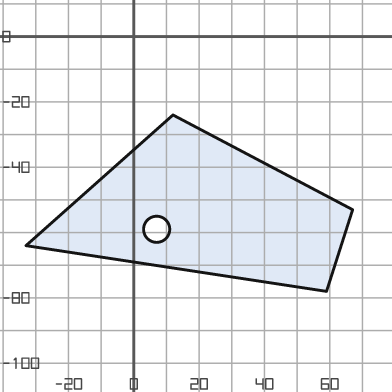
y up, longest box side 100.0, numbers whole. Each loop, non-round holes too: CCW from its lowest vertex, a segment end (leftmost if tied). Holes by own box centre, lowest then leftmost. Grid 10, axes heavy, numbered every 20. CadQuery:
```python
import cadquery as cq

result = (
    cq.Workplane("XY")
    .moveTo(59.0, -78.0)
    .lineTo(67.0, -53.0)
    .lineTo(12.0, -24.0)
    .lineTo(-33.0, -64.0)
    .close()
    .moveTo(7.0, -59.0)
    .circle(4.0)
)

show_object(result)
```